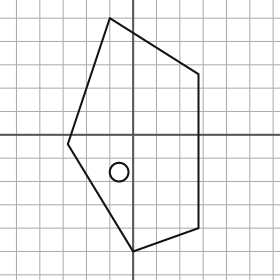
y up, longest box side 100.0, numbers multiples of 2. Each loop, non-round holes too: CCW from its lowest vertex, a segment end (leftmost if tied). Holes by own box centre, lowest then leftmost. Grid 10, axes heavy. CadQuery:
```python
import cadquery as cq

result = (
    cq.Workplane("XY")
    .moveTo(0.0, -50.0)
    .lineTo(28.0, -40.0)
    .lineTo(28.0, 26.0)
    .lineTo(-10.0, 50.0)
    .lineTo(-28.0, -4.0)
    .close()
    .moveTo(-6.0, -16.0)
    .circle(4.0)
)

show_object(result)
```